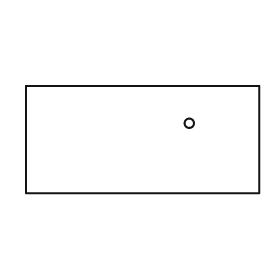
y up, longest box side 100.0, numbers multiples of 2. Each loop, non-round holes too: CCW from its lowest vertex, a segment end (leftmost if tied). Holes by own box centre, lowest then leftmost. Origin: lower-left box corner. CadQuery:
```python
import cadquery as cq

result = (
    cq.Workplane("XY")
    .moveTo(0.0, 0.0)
    .lineTo(100.0, 0.0)
    .lineTo(100.0, 46.0)
    .lineTo(0.0, 46.0)
    .close()
    .moveTo(70.0, 30.0)
    .circle(2.0)
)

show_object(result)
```